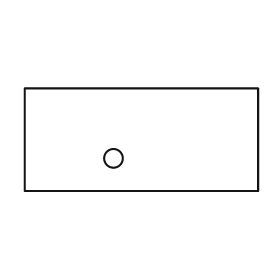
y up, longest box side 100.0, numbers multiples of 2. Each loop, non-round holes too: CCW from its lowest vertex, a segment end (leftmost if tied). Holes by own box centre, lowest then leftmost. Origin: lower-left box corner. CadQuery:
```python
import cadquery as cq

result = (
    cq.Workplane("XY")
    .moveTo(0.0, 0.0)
    .lineTo(100.0, 0.0)
    .lineTo(100.0, 44.0)
    .lineTo(0.0, 44.0)
    .close()
    .moveTo(38.0, 14.0)
    .circle(4.0)
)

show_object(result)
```